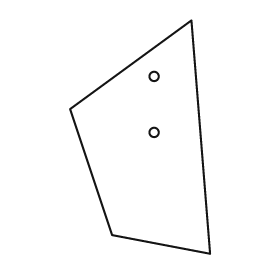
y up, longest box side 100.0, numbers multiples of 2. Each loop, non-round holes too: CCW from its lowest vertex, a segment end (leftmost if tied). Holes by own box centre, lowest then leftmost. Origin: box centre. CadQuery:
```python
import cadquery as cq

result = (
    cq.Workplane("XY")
    .moveTo(30.0, -50.0)
    .lineTo(22.0, 50.0)
    .lineTo(-30.0, 12.0)
    .lineTo(-12.0, -42.0)
    .close()
    .moveTo(6.0, 2.0)
    .circle(2.0)
    .moveTo(6.0, 26.0)
    .circle(2.0)
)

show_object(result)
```